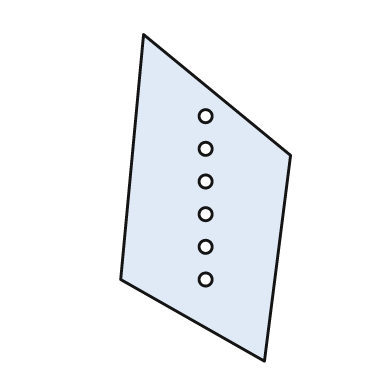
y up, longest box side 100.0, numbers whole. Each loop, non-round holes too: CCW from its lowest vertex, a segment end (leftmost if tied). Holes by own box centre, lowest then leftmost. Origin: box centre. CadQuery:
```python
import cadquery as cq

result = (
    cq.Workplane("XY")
    .moveTo(18.0, -50.0)
    .lineTo(26.0, 13.0)
    .lineTo(-19.0, 50.0)
    .lineTo(-26.0, -25.0)
    .close()
    .moveTo(0.0, -25.0)
    .circle(2.0)
    .moveTo(0.0, -15.0)
    .circle(2.0)
    .moveTo(0.0, -5.0)
    .circle(2.0)
    .moveTo(0.0, 5.0)
    .circle(2.0)
    .moveTo(0.0, 15.0)
    .circle(2.0)
    .moveTo(0.0, 25.0)
    .circle(2.0)
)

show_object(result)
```